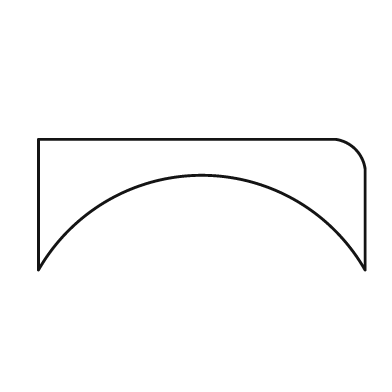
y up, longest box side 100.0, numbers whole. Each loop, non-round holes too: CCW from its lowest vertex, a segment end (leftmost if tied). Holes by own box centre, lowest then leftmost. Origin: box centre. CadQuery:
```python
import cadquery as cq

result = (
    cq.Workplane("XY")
    .moveTo(-50.0, -20.0)
    .threePointArc((0.0, 9.0), (50.0, -20.0))
    .lineTo(50.0, 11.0)
    .threePointArc((47.0, 17.0), (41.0, 20.0))
    .lineTo(-50.0, 20.0)
    .close()
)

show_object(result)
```